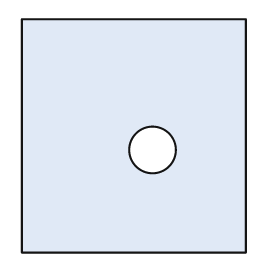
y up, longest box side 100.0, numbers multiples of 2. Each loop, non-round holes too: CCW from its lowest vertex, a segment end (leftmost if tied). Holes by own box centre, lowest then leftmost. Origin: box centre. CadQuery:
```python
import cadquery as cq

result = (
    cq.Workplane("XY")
    .moveTo(-48.0, -50.0)
    .lineTo(48.0, -50.0)
    .lineTo(48.0, 50.0)
    .lineTo(-48.0, 50.0)
    .close()
    .moveTo(8.0, -6.0)
    .circle(10.0)
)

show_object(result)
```